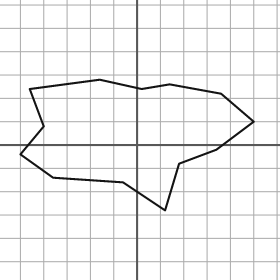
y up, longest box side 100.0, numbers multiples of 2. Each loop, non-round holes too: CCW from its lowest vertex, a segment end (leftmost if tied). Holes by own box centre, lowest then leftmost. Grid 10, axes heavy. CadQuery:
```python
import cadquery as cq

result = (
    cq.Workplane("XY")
    .moveTo(12.0, -28.0)
    .lineTo(18.0, -8.0)
    .lineTo(34.0, -2.0)
    .lineTo(50.0, 10.0)
    .lineTo(36.0, 22.0)
    .lineTo(14.0, 26.0)
    .lineTo(2.0, 24.0)
    .lineTo(-16.0, 28.0)
    .lineTo(-46.0, 24.0)
    .lineTo(-40.0, 8.0)
    .lineTo(-50.0, -4.0)
    .lineTo(-36.0, -14.0)
    .lineTo(-6.0, -16.0)
    .close()
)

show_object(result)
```